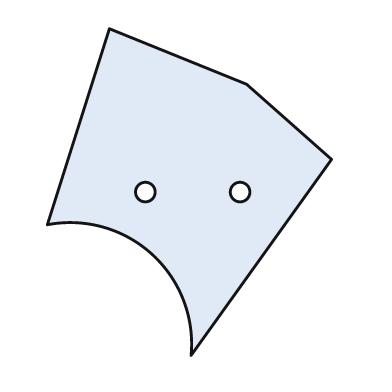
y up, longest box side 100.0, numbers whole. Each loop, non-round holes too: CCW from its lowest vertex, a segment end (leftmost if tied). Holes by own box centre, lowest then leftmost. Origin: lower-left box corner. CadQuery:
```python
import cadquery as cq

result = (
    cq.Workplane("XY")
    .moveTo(44.0, 0.0)
    .lineTo(87.0, 60.0)
    .lineTo(61.0, 83.0)
    .lineTo(19.0, 100.0)
    .lineTo(0.0, 40.0)
    .threePointArc((32.0, 31.0), (44.0, 0.0))
    .close()
    .moveTo(30.0, 50.0)
    .circle(3.0)
    .moveTo(59.0, 50.0)
    .circle(3.0)
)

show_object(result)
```